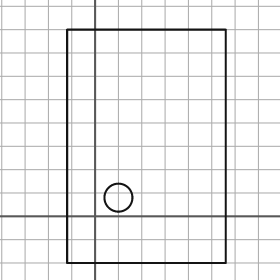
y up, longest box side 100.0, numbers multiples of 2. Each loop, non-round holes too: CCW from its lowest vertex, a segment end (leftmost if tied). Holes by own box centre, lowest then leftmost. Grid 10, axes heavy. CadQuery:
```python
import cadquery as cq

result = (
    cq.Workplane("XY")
    .moveTo(-12.0, -20.0)
    .lineTo(56.0, -20.0)
    .lineTo(56.0, 80.0)
    .lineTo(-12.0, 80.0)
    .close()
    .moveTo(10.0, 8.0)
    .circle(6.0)
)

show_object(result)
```